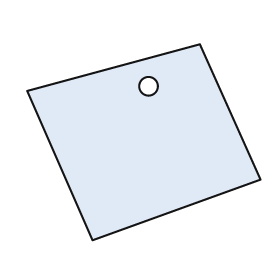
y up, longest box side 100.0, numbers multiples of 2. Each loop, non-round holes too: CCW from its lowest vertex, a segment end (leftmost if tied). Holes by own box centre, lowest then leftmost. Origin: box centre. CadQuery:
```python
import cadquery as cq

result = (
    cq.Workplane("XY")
    .moveTo(-22.0, -42.0)
    .lineTo(50.0, -16.0)
    .lineTo(24.0, 42.0)
    .lineTo(-50.0, 22.0)
    .close()
    .moveTo(2.0, 24.0)
    .circle(4.0)
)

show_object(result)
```